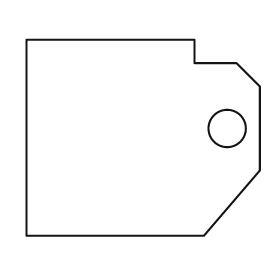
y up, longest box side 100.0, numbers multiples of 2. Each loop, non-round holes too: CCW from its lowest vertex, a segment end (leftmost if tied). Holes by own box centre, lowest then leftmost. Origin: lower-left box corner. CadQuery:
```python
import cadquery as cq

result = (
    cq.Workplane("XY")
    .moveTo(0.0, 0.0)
    .lineTo(76.0, 0.0)
    .lineTo(100.0, 28.0)
    .lineTo(100.0, 64.0)
    .lineTo(90.0, 74.0)
    .lineTo(72.0, 74.0)
    .lineTo(72.0, 84.0)
    .lineTo(0.0, 84.0)
    .close()
    .moveTo(86.0, 46.0)
    .circle(8.0)
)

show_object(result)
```